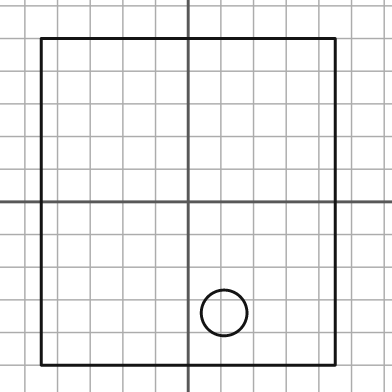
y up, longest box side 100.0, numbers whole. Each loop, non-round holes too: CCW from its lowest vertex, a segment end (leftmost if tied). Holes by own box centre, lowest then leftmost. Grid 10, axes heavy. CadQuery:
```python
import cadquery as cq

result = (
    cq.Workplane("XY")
    .moveTo(-45.0, -50.0)
    .lineTo(45.0, -50.0)
    .lineTo(45.0, 50.0)
    .lineTo(-45.0, 50.0)
    .close()
    .moveTo(11.0, -34.0)
    .circle(7.0)
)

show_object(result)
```